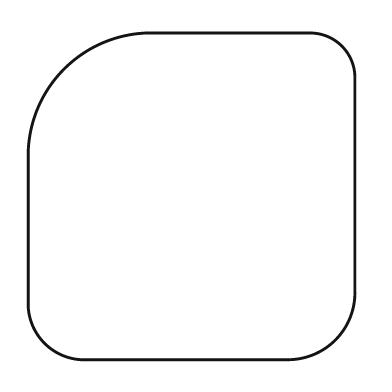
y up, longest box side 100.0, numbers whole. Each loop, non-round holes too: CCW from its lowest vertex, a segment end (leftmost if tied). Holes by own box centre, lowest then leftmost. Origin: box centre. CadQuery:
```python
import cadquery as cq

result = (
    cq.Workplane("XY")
    .moveTo(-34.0, -50.0)
    .lineTo(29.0, -50.0)
    .threePointArc((44.0, -44.0), (50.0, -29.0))
    .lineTo(50.0, 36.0)
    .threePointArc((46.0, 46.0), (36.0, 50.0))
    .lineTo(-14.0, 50.0)
    .threePointArc((-39.0, 39.0), (-50.0, 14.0))
    .lineTo(-50.0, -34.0)
    .threePointArc((-45.0, -45.0), (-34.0, -50.0))
    .close()
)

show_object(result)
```